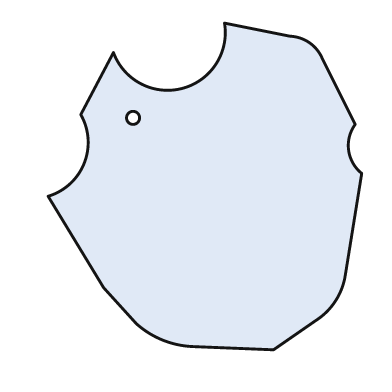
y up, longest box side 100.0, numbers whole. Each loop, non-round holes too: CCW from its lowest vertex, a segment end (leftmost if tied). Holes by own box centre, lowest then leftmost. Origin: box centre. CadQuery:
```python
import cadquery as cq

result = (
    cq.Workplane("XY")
    .moveTo(21.0, -50.0)
    .lineTo(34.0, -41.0)
    .threePointArc((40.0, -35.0), (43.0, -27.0))
    .lineTo(48.0, 4.0)
    .threePointArc((44.0, 11.0), (46.0, 19.0))
    .lineTo(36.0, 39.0)
    .threePointArc((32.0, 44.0), (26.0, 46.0))
    .lineTo(6.0, 50.0)
    .threePointArc((-7.0, 30.0), (-28.0, 41.0))
    .lineTo(-38.0, 22.0)
    .threePointArc((-37.0, 7.0), (-48.0, -3.0))
    .lineTo(-31.0, -31.0)
    .lineTo(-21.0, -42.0)
    .threePointArc((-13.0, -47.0), (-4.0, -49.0))
    .close()
    .moveTo(-22.0, 21.0)
    .circle(2.0)
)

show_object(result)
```